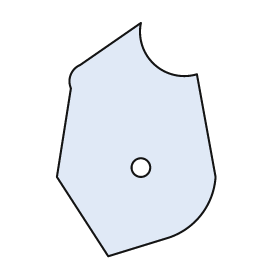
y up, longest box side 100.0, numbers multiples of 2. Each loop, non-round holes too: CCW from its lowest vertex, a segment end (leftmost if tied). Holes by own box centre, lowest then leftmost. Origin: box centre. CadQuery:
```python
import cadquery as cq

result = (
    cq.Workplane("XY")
    .moveTo(-12.0, -50.0)
    .lineTo(14.0, -42.0)
    .threePointArc((28.0, -32.0), (34.0, -16.0))
    .lineTo(26.0, 28.0)
    .threePointArc((8.0, 32.0), (2.0, 50.0))
    .lineTo(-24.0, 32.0)
    .threePointArc((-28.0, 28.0), (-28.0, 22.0))
    .lineTo(-34.0, -16.0)
    .close()
    .moveTo(2.0, -12.0)
    .circle(4.0)
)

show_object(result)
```